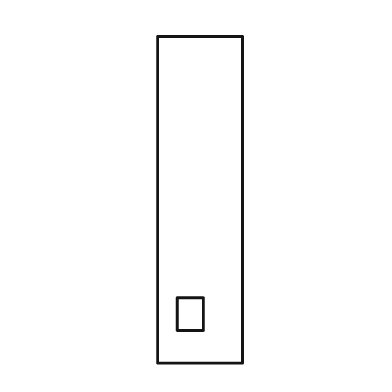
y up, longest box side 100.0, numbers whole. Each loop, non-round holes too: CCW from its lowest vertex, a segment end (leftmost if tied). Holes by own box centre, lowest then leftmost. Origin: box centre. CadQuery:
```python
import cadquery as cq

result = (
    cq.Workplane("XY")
    .moveTo(-13.0, -50.0)
    .lineTo(13.0, -50.0)
    .lineTo(13.0, 50.0)
    .lineTo(-13.0, 50.0)
    .close()
    .moveTo(-7.0, -40.0)
    .lineTo(1.0, -40.0)
    .lineTo(1.0, -30.0)
    .lineTo(-7.0, -30.0)
    .close()
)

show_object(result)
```